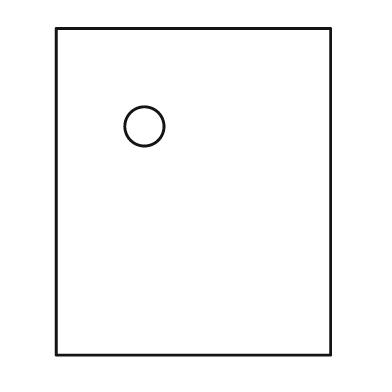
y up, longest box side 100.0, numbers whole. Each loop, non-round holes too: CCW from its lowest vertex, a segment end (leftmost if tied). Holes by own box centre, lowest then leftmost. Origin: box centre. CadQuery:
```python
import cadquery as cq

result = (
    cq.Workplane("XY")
    .moveTo(-42.0, -50.0)
    .lineTo(42.0, -50.0)
    .lineTo(42.0, 50.0)
    .lineTo(-42.0, 50.0)
    .close()
    .moveTo(-15.0, 20.0)
    .circle(6.0)
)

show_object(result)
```